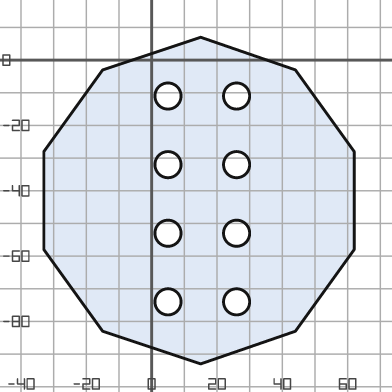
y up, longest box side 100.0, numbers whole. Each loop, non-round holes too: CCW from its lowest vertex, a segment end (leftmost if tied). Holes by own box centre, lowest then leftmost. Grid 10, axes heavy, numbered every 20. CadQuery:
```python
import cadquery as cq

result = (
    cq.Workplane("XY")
    .moveTo(15.0, -93.0)
    .lineTo(44.0, -83.0)
    .lineTo(62.0, -58.0)
    .lineTo(62.0, -28.0)
    .lineTo(44.0, -3.0)
    .lineTo(15.0, 7.0)
    .lineTo(-15.0, -3.0)
    .lineTo(-33.0, -28.0)
    .lineTo(-33.0, -58.0)
    .lineTo(-15.0, -83.0)
    .close()
    .moveTo(5.0, -74.0)
    .circle(4.0)
    .moveTo(26.0, -74.0)
    .circle(4.0)
    .moveTo(5.0, -53.0)
    .circle(4.0)
    .moveTo(26.0, -53.0)
    .circle(4.0)
    .moveTo(5.0, -32.0)
    .circle(4.0)
    .moveTo(26.0, -32.0)
    .circle(4.0)
    .moveTo(5.0, -11.0)
    .circle(4.0)
    .moveTo(26.0, -11.0)
    .circle(4.0)
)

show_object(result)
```